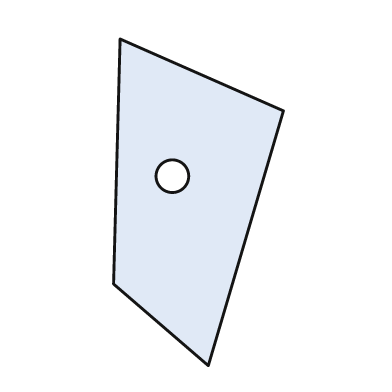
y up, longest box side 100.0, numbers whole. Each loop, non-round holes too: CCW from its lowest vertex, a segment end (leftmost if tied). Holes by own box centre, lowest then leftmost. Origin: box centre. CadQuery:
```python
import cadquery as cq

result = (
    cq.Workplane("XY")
    .moveTo(3.0, -50.0)
    .lineTo(26.0, 28.0)
    .lineTo(-24.0, 50.0)
    .lineTo(-26.0, -25.0)
    .close()
    .moveTo(-8.0, 8.0)
    .circle(5.0)
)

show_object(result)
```